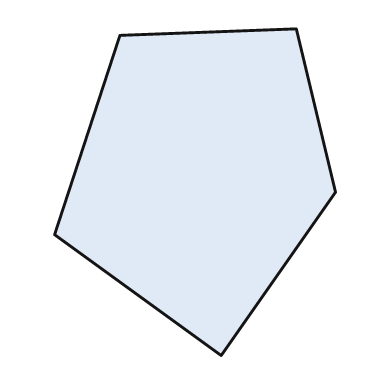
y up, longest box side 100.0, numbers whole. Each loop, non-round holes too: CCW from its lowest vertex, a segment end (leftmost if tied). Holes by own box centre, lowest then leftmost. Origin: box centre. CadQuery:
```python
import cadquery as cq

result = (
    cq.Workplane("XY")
    .moveTo(8.0, -50.0)
    .lineTo(43.0, 0.0)
    .lineTo(31.0, 50.0)
    .lineTo(-23.0, 48.0)
    .lineTo(-43.0, -13.0)
    .close()
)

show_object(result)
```